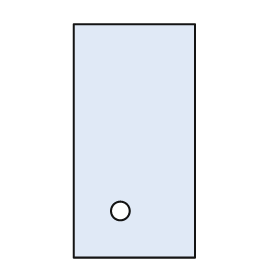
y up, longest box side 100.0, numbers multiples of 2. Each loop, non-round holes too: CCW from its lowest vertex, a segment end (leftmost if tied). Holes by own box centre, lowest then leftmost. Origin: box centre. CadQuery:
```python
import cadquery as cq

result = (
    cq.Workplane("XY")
    .moveTo(-26.0, -50.0)
    .lineTo(26.0, -50.0)
    .lineTo(26.0, 50.0)
    .lineTo(-26.0, 50.0)
    .close()
    .moveTo(-6.0, -30.0)
    .circle(4.0)
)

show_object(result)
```